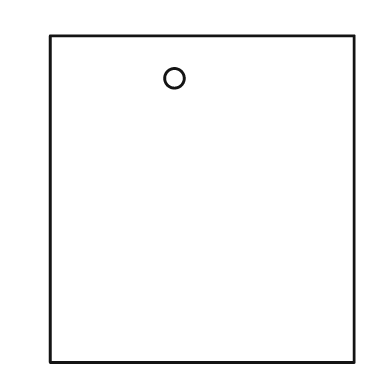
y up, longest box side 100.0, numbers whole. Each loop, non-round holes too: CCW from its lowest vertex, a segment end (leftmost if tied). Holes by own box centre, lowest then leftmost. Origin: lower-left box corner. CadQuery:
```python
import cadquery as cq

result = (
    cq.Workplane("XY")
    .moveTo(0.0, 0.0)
    .lineTo(93.0, 0.0)
    .lineTo(93.0, 100.0)
    .lineTo(0.0, 100.0)
    .close()
    .moveTo(38.0, 87.0)
    .circle(3.0)
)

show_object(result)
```